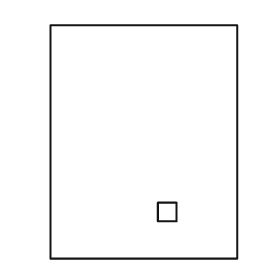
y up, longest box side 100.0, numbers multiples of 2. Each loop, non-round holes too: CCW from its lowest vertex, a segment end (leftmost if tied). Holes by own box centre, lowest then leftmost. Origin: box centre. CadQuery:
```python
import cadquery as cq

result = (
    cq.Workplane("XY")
    .moveTo(-40.0, -50.0)
    .lineTo(40.0, -50.0)
    .lineTo(40.0, 50.0)
    .lineTo(-40.0, 50.0)
    .close()
    .moveTo(6.0, -34.0)
    .lineTo(14.0, -34.0)
    .lineTo(14.0, -26.0)
    .lineTo(6.0, -26.0)
    .close()
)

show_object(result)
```